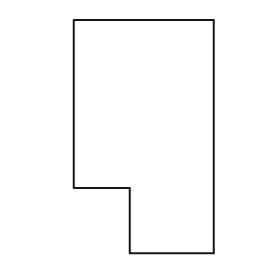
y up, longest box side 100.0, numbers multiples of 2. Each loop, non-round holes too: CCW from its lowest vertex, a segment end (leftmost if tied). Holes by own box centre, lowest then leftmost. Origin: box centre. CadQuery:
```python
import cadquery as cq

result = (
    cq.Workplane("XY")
    .moveTo(-6.0, -50.0)
    .lineTo(30.0, -50.0)
    .lineTo(30.0, 50.0)
    .lineTo(-30.0, 50.0)
    .lineTo(-30.0, -22.0)
    .lineTo(-6.0, -22.0)
    .close()
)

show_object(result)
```